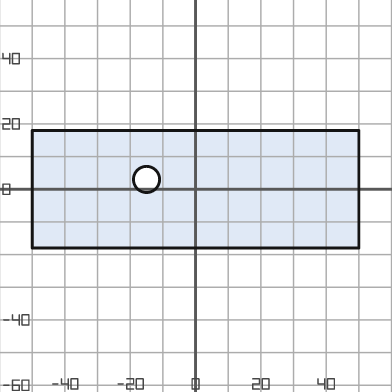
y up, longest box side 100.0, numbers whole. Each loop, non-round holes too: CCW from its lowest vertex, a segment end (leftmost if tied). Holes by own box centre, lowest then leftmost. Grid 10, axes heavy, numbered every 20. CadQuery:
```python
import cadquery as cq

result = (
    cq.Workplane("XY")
    .moveTo(-50.0, -18.0)
    .lineTo(50.0, -18.0)
    .lineTo(50.0, 18.0)
    .lineTo(-50.0, 18.0)
    .close()
    .moveTo(-15.0, 3.0)
    .circle(4.0)
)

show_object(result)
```